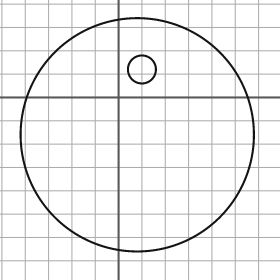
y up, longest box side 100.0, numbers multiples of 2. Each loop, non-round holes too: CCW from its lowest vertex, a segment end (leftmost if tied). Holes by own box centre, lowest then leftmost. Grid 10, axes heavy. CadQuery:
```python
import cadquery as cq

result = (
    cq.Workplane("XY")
    .moveTo(8.0, -16.0)
    .circle(50.0)
    .moveTo(10.0, 12.0)
    .circle(6.0)
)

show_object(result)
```